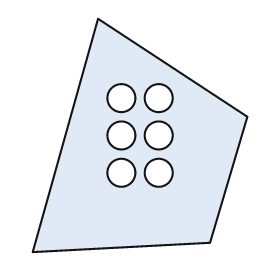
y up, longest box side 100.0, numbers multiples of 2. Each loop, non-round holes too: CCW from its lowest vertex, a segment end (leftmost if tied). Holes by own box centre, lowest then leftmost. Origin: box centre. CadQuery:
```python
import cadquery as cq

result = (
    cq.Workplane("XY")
    .moveTo(-46.0, -50.0)
    .lineTo(30.0, -46.0)
    .lineTo(46.0, 8.0)
    .lineTo(-18.0, 50.0)
    .close()
    .moveTo(-8.0, -16.0)
    .circle(6.0)
    .moveTo(8.0, -16.0)
    .circle(6.0)
    .moveTo(-8.0, 0.0)
    .circle(6.0)
    .moveTo(8.0, 0.0)
    .circle(6.0)
    .moveTo(-8.0, 16.0)
    .circle(6.0)
    .moveTo(8.0, 16.0)
    .circle(6.0)
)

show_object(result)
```